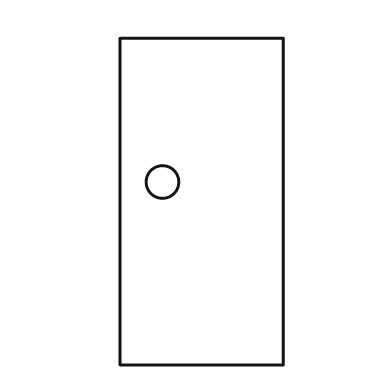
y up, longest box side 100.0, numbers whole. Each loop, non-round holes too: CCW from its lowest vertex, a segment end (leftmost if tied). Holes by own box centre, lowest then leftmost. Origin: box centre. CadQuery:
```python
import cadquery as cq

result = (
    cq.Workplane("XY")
    .moveTo(-25.0, -50.0)
    .lineTo(25.0, -50.0)
    .lineTo(25.0, 50.0)
    .lineTo(-25.0, 50.0)
    .close()
    .moveTo(-12.0, 6.0)
    .circle(5.0)
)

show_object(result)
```